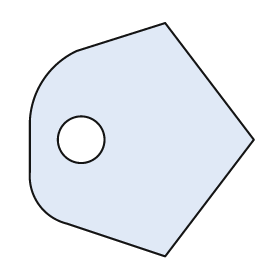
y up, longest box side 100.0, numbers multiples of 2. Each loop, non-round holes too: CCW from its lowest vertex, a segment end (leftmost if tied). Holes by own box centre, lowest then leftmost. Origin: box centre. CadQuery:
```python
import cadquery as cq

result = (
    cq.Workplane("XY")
    .moveTo(10.0, -50.0)
    .lineTo(48.0, 0.0)
    .lineTo(10.0, 50.0)
    .lineTo(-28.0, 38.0)
    .threePointArc((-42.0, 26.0), (-48.0, 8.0))
    .lineTo(-48.0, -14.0)
    .threePointArc((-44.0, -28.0), (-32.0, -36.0))
    .close()
    .moveTo(-26.0, 0.0)
    .circle(10.0)
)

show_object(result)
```